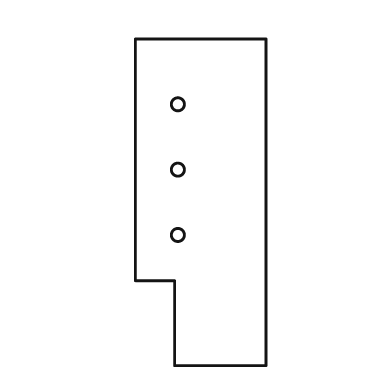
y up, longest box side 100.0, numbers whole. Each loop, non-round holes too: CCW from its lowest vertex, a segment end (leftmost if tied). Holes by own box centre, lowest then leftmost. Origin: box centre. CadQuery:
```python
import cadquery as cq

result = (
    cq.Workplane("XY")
    .moveTo(-8.0, -50.0)
    .lineTo(20.0, -50.0)
    .lineTo(20.0, 50.0)
    .lineTo(-20.0, 50.0)
    .lineTo(-20.0, -24.0)
    .lineTo(-8.0, -24.0)
    .close()
    .moveTo(-7.0, -10.0)
    .circle(2.0)
    .moveTo(-7.0, 10.0)
    .circle(2.0)
    .moveTo(-7.0, 30.0)
    .circle(2.0)
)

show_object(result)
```